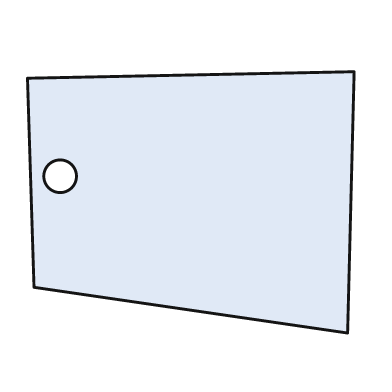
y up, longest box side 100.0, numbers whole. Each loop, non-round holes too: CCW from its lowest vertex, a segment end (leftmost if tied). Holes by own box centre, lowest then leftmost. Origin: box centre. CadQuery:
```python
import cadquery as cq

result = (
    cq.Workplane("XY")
    .moveTo(48.0, -40.0)
    .lineTo(50.0, 40.0)
    .lineTo(-50.0, 38.0)
    .lineTo(-48.0, -26.0)
    .close()
    .moveTo(-40.0, 8.0)
    .circle(5.0)
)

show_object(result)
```